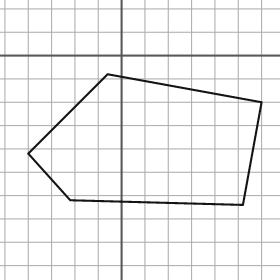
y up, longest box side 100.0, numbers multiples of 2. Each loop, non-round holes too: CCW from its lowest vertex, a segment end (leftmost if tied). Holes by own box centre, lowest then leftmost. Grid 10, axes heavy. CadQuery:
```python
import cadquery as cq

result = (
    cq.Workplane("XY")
    .moveTo(52.0, -64.0)
    .lineTo(60.0, -20.0)
    .lineTo(-6.0, -8.0)
    .lineTo(-40.0, -42.0)
    .lineTo(-22.0, -62.0)
    .close()
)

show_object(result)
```